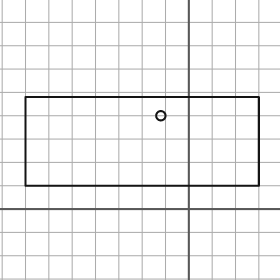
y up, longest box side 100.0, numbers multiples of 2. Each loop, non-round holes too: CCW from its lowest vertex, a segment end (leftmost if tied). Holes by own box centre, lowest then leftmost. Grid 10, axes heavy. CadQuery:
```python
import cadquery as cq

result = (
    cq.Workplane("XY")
    .moveTo(-70.0, 10.0)
    .lineTo(30.0, 10.0)
    .lineTo(30.0, 48.0)
    .lineTo(-70.0, 48.0)
    .close()
    .moveTo(-12.0, 40.0)
    .circle(2.0)
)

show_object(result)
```